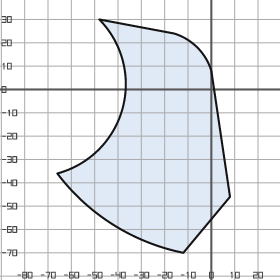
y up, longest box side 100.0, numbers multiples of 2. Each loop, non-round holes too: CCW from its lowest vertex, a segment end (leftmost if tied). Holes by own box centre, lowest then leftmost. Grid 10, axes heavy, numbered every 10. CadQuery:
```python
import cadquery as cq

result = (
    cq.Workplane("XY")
    .moveTo(-12.0, -70.0)
    .lineTo(8.0, -46.0)
    .lineTo(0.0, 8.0)
    .threePointArc((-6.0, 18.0), (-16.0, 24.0))
    .lineTo(-48.0, 30.0)
    .threePointArc((-38.0, -8.0), (-66.0, -36.0))
    .threePointArc((-42.0, -58.0), (-12.0, -70.0))
    .close()
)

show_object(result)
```